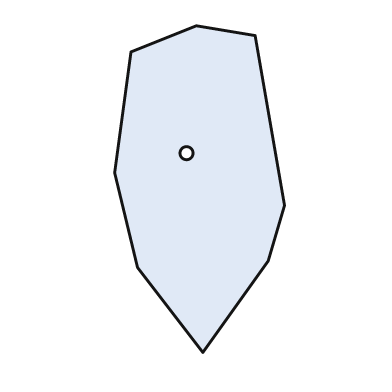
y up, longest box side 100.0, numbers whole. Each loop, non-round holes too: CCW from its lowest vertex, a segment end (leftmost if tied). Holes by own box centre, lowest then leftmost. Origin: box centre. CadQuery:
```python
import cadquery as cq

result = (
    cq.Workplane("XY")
    .moveTo(1.0, -50.0)
    .lineTo(21.0, -22.0)
    .lineTo(26.0, -5.0)
    .lineTo(17.0, 47.0)
    .lineTo(-1.0, 50.0)
    .lineTo(-21.0, 42.0)
    .lineTo(-26.0, 5.0)
    .lineTo(-19.0, -24.0)
    .close()
    .moveTo(-4.0, 11.0)
    .circle(2.0)
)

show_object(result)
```